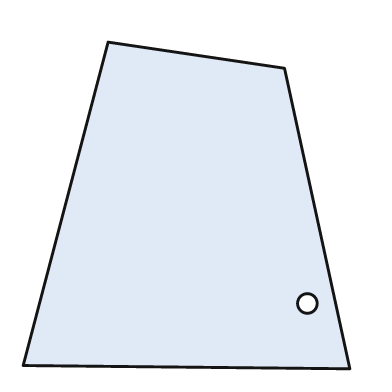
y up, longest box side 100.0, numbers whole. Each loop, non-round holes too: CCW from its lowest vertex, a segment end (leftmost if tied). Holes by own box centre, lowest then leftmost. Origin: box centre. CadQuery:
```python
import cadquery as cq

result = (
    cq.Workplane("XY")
    .moveTo(50.0, -50.0)
    .lineTo(30.0, 42.0)
    .lineTo(-24.0, 50.0)
    .lineTo(-50.0, -49.0)
    .close()
    .moveTo(37.0, -30.0)
    .circle(3.0)
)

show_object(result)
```